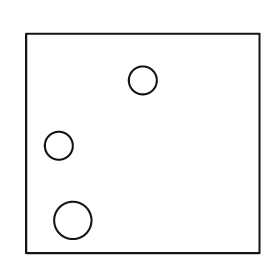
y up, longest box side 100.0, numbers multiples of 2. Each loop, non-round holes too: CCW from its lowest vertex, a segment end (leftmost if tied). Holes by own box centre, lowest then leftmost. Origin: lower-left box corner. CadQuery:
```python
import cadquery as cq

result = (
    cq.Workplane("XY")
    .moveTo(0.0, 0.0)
    .lineTo(100.0, 0.0)
    .lineTo(100.0, 94.0)
    .lineTo(0.0, 94.0)
    .close()
    .moveTo(20.0, 14.0)
    .circle(8.0)
    .moveTo(14.0, 46.0)
    .circle(6.0)
    .moveTo(50.0, 74.0)
    .circle(6.0)
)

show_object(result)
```